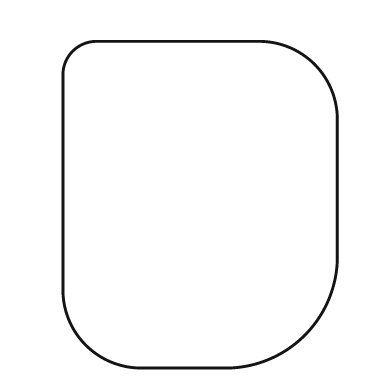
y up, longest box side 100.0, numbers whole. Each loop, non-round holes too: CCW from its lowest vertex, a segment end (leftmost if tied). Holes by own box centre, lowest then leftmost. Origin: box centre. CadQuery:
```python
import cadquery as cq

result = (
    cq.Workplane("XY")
    .moveTo(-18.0, -50.0)
    .lineTo(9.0, -50.0)
    .threePointArc((32.0, -40.0), (42.0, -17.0))
    .lineTo(42.0, 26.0)
    .threePointArc((35.0, 43.0), (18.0, 50.0))
    .lineTo(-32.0, 50.0)
    .threePointArc((-39.0, 47.0), (-42.0, 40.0))
    .lineTo(-42.0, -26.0)
    .threePointArc((-35.0, -43.0), (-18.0, -50.0))
    .close()
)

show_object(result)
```